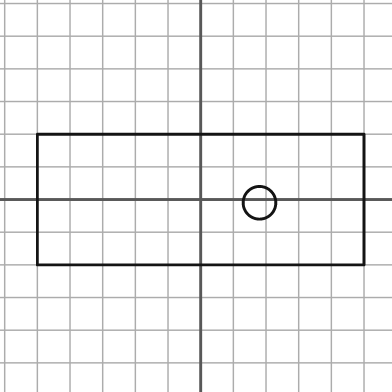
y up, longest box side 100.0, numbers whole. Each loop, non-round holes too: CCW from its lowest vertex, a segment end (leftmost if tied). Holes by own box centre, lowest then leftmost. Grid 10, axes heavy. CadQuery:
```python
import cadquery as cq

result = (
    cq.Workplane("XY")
    .moveTo(-50.0, -20.0)
    .lineTo(50.0, -20.0)
    .lineTo(50.0, 20.0)
    .lineTo(-50.0, 20.0)
    .close()
    .moveTo(18.0, -1.0)
    .circle(5.0)
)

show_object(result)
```